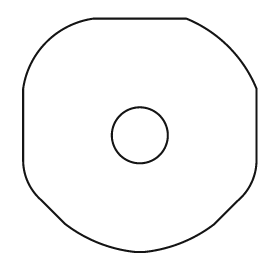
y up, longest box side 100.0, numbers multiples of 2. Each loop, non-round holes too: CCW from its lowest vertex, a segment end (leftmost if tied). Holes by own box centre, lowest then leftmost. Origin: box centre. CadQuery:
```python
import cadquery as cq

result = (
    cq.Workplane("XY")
    .moveTo(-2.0, -50.0)
    .lineTo(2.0, -50.0)
    .threePointArc((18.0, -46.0), (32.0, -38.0))
    .lineTo(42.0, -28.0)
    .threePointArc((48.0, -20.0), (50.0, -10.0))
    .lineTo(50.0, 20.0)
    .threePointArc((38.0, 38.0), (20.0, 50.0))
    .lineTo(-20.0, 50.0)
    .threePointArc((-40.0, 40.0), (-50.0, 20.0))
    .lineTo(-50.0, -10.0)
    .threePointArc((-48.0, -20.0), (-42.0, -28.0))
    .lineTo(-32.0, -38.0)
    .threePointArc((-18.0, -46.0), (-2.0, -50.0))
    .close()
    .moveTo(0.0, 0.0)
    .circle(12.0)
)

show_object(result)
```